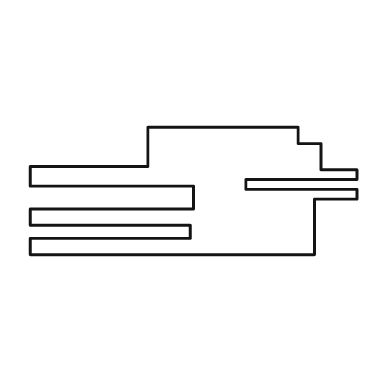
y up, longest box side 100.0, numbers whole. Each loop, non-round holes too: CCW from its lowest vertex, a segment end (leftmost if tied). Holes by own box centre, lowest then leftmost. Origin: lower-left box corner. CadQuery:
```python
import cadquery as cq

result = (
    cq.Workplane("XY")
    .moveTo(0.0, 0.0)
    .lineTo(87.0, 0.0)
    .lineTo(87.0, 17.0)
    .lineTo(100.0, 17.0)
    .lineTo(100.0, 20.0)
    .lineTo(66.0, 20.0)
    .lineTo(66.0, 23.0)
    .lineTo(100.0, 23.0)
    .lineTo(100.0, 26.0)
    .lineTo(89.0, 26.0)
    .lineTo(89.0, 34.0)
    .lineTo(82.0, 34.0)
    .lineTo(82.0, 39.0)
    .lineTo(36.0, 39.0)
    .lineTo(36.0, 27.0)
    .lineTo(0.0, 27.0)
    .lineTo(0.0, 21.0)
    .lineTo(50.0, 21.0)
    .lineTo(50.0, 14.0)
    .lineTo(0.0, 14.0)
    .lineTo(0.0, 9.0)
    .lineTo(49.0, 9.0)
    .lineTo(49.0, 5.0)
    .lineTo(0.0, 5.0)
    .close()
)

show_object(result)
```